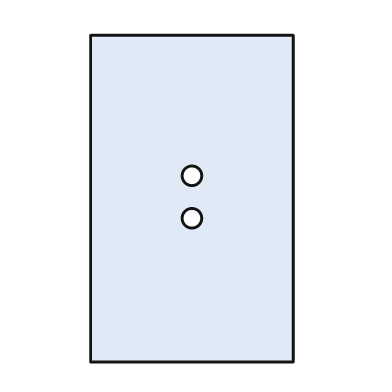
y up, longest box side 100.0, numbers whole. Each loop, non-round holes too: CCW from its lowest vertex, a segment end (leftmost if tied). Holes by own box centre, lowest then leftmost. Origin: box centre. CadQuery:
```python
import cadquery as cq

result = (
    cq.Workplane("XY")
    .moveTo(-31.0, -50.0)
    .lineTo(31.0, -50.0)
    .lineTo(31.0, 50.0)
    .lineTo(-31.0, 50.0)
    .close()
    .moveTo(0.0, -6.0)
    .circle(3.0)
    .moveTo(0.0, 7.0)
    .circle(3.0)
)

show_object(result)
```